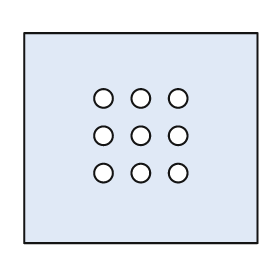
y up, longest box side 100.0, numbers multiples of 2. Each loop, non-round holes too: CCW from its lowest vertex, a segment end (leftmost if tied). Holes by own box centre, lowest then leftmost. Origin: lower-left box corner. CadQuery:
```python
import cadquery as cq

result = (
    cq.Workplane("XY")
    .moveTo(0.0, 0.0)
    .lineTo(100.0, 0.0)
    .lineTo(100.0, 90.0)
    .lineTo(0.0, 90.0)
    .close()
    .moveTo(34.0, 30.0)
    .circle(4.0)
    .moveTo(50.0, 30.0)
    .circle(4.0)
    .moveTo(66.0, 30.0)
    .circle(4.0)
    .moveTo(34.0, 46.0)
    .circle(4.0)
    .moveTo(50.0, 46.0)
    .circle(4.0)
    .moveTo(66.0, 46.0)
    .circle(4.0)
    .moveTo(34.0, 62.0)
    .circle(4.0)
    .moveTo(50.0, 62.0)
    .circle(4.0)
    .moveTo(66.0, 62.0)
    .circle(4.0)
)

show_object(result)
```